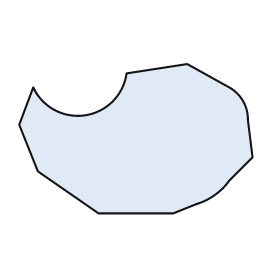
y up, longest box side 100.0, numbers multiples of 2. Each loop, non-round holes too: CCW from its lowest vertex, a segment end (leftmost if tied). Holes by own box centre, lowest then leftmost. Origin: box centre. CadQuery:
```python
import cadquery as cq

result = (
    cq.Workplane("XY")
    .moveTo(-16.0, -32.0)
    .lineTo(16.0, -32.0)
    .lineTo(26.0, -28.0)
    .threePointArc((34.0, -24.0), (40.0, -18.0))
    .lineTo(50.0, -8.0)
    .lineTo(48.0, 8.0)
    .threePointArc((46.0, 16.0), (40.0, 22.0))
    .lineTo(22.0, 32.0)
    .lineTo(-4.0, 28.0)
    .threePointArc((-22.0, 10.0), (-44.0, 22.0))
    .lineTo(-50.0, 6.0)
    .lineTo(-42.0, -14.0)
    .close()
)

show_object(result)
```